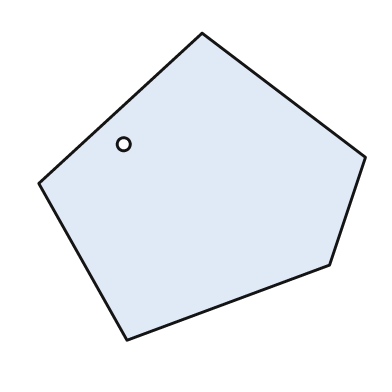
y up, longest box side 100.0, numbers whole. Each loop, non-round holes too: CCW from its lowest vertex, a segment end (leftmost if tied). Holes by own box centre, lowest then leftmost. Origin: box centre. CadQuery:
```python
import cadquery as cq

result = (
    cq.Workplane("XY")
    .moveTo(-23.0, -47.0)
    .lineTo(39.0, -24.0)
    .lineTo(50.0, 9.0)
    .lineTo(0.0, 47.0)
    .lineTo(-50.0, 1.0)
    .close()
    .moveTo(-24.0, 13.0)
    .circle(2.0)
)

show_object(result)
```